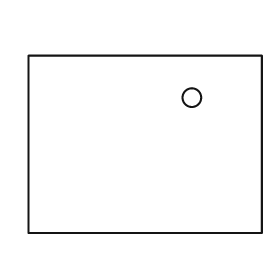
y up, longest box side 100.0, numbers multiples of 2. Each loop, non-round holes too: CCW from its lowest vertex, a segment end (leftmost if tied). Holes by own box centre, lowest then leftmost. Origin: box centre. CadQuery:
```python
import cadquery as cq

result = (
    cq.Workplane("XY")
    .moveTo(-50.0, -38.0)
    .lineTo(50.0, -38.0)
    .lineTo(50.0, 38.0)
    .lineTo(-50.0, 38.0)
    .close()
    .moveTo(20.0, 20.0)
    .circle(4.0)
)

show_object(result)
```